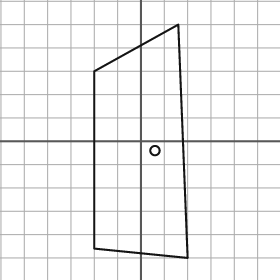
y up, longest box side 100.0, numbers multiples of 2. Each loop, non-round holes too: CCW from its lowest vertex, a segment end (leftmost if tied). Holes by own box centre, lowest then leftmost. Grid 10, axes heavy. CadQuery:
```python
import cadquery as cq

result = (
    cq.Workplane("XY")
    .moveTo(20.0, -50.0)
    .lineTo(16.0, 50.0)
    .lineTo(-20.0, 30.0)
    .lineTo(-20.0, -46.0)
    .close()
    .moveTo(6.0, -4.0)
    .circle(2.0)
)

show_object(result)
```